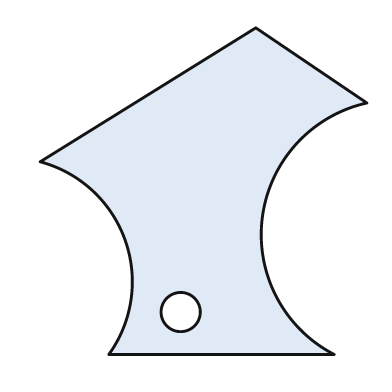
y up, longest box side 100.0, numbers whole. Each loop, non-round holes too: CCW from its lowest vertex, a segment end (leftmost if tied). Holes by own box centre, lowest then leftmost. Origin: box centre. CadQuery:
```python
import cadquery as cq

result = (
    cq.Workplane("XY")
    .moveTo(-29.0, -50.0)
    .lineTo(40.0, -50.0)
    .threePointArc((18.0, -8.0), (50.0, 27.0))
    .lineTo(16.0, 50.0)
    .lineTo(-50.0, 9.0)
    .threePointArc((-24.0, -15.0), (-29.0, -50.0))
    .close()
    .moveTo(-7.0, -37.0)
    .circle(6.0)
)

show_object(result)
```